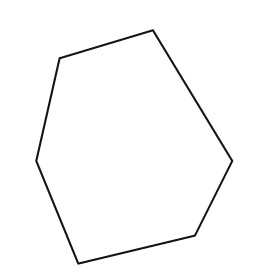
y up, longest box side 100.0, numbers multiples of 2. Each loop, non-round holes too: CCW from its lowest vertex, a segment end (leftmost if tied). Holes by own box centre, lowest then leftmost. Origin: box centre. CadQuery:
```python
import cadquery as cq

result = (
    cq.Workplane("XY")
    .moveTo(-24.0, -50.0)
    .lineTo(26.0, -38.0)
    .lineTo(42.0, -6.0)
    .lineTo(8.0, 50.0)
    .lineTo(-32.0, 38.0)
    .lineTo(-42.0, -6.0)
    .close()
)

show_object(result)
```